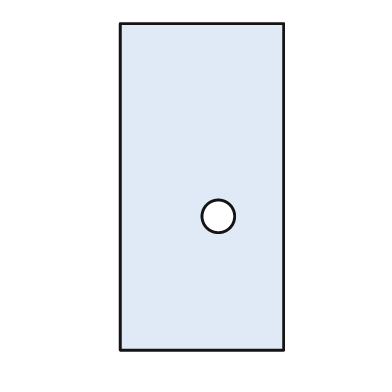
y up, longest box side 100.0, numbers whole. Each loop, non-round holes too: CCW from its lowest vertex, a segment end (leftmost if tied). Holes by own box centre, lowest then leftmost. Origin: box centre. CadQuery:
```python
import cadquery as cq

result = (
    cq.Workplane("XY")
    .moveTo(-25.0, -50.0)
    .lineTo(25.0, -50.0)
    .lineTo(25.0, 50.0)
    .lineTo(-25.0, 50.0)
    .close()
    .moveTo(5.0, -9.0)
    .circle(5.0)
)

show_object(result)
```